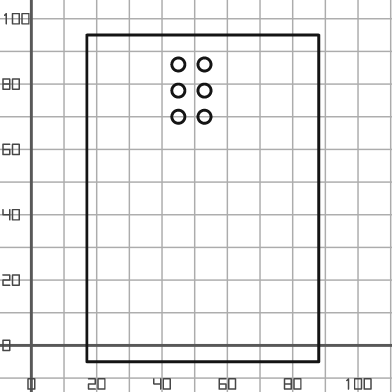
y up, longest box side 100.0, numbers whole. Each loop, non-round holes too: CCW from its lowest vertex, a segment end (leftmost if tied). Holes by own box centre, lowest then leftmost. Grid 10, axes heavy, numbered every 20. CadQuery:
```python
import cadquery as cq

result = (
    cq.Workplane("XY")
    .moveTo(17.0, -5.0)
    .lineTo(88.0, -5.0)
    .lineTo(88.0, 95.0)
    .lineTo(17.0, 95.0)
    .close()
    .moveTo(45.0, 70.0)
    .circle(2.0)
    .moveTo(53.0, 70.0)
    .circle(2.0)
    .moveTo(45.0, 78.0)
    .circle(2.0)
    .moveTo(53.0, 78.0)
    .circle(2.0)
    .moveTo(45.0, 86.0)
    .circle(2.0)
    .moveTo(53.0, 86.0)
    .circle(2.0)
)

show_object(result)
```